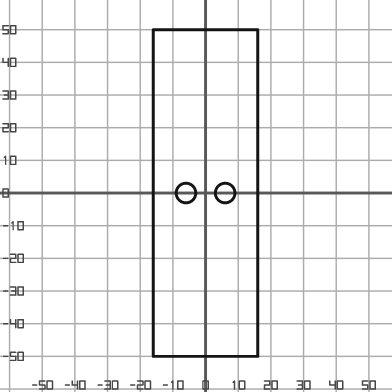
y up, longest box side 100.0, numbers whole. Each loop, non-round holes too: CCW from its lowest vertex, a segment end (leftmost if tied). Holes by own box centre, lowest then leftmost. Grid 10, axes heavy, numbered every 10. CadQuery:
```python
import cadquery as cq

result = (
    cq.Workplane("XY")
    .moveTo(-16.0, -50.0)
    .lineTo(16.0, -50.0)
    .lineTo(16.0, 50.0)
    .lineTo(-16.0, 50.0)
    .close()
    .moveTo(-6.0, 0.0)
    .circle(3.0)
    .moveTo(6.0, 0.0)
    .circle(3.0)
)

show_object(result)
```